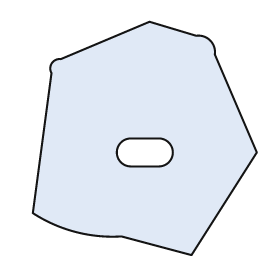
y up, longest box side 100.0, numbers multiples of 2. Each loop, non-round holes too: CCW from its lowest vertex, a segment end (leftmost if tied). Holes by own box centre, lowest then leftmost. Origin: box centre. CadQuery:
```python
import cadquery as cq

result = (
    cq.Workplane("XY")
    .moveTo(20.0, -50.0)
    .lineTo(48.0, -6.0)
    .lineTo(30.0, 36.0)
    .threePointArc((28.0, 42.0), (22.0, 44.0))
    .lineTo(2.0, 50.0)
    .lineTo(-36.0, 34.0)
    .threePointArc((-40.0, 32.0), (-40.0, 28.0))
    .lineTo(-48.0, -32.0)
    .threePointArc((-30.0, -40.0), (-10.0, -42.0))
    .close()
    .moveTo(-6.0, -12.0)
    .lineTo(6.0, -12.0)
    .threePointArc((12.0, -6.0), (6.0, 0.0))
    .lineTo(-6.0, 0.0)
    .threePointArc((-12.0, -6.0), (-6.0, -12.0))
    .close()
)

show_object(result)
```